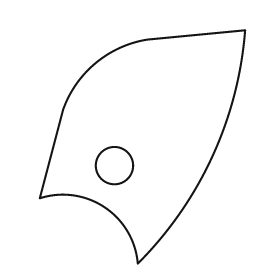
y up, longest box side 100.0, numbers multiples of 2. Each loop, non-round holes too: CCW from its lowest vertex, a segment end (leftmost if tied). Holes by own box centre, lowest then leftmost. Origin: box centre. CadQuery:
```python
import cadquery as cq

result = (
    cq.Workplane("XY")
    .moveTo(-2.0, -50.0)
    .threePointArc((30.0, -4.0), (44.0, 50.0))
    .lineTo(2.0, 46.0)
    .threePointArc((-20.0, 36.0), (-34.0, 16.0))
    .lineTo(-44.0, -22.0)
    .threePointArc((-16.0, -26.0), (-2.0, -50.0))
    .close()
    .moveTo(-12.0, -8.0)
    .circle(8.0)
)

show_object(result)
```